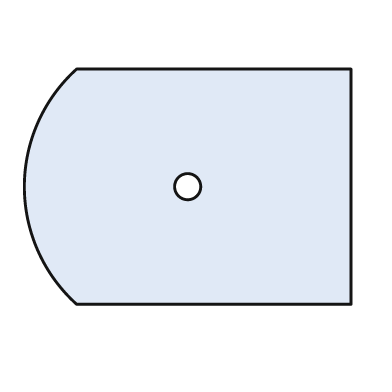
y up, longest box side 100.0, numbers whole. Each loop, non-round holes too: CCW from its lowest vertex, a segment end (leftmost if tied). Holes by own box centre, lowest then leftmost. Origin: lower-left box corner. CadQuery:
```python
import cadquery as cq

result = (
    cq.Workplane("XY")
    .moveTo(16.0, 0.0)
    .lineTo(100.0, 0.0)
    .lineTo(100.0, 72.0)
    .lineTo(16.0, 72.0)
    .threePointArc((0.0, 36.0), (16.0, 0.0))
    .close()
    .moveTo(50.0, 36.0)
    .circle(4.0)
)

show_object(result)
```